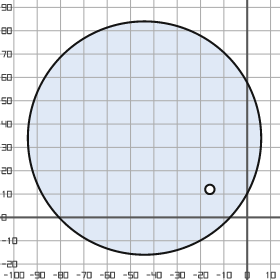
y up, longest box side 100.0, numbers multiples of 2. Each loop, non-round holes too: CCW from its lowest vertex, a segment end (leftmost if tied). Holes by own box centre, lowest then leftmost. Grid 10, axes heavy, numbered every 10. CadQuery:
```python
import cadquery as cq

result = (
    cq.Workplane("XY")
    .moveTo(-44.0, 34.0)
    .circle(50.0)
    .moveTo(-16.0, 12.0)
    .circle(2.0)
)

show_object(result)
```